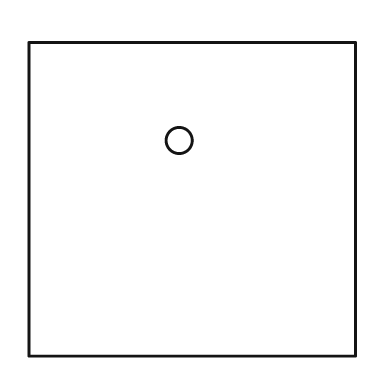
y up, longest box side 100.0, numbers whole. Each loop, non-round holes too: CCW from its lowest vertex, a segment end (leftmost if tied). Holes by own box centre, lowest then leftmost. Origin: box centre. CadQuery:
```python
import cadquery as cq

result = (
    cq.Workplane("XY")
    .moveTo(-50.0, -48.0)
    .lineTo(50.0, -48.0)
    .lineTo(50.0, 48.0)
    .lineTo(-50.0, 48.0)
    .close()
    .moveTo(-4.0, 18.0)
    .circle(4.0)
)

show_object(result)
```